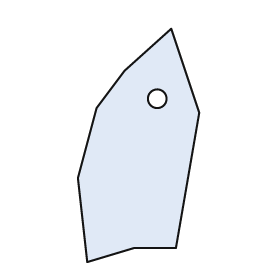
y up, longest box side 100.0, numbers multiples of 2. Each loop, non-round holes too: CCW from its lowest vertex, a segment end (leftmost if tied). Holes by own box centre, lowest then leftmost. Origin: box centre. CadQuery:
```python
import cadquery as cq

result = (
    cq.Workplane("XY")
    .moveTo(-22.0, -50.0)
    .lineTo(-2.0, -44.0)
    .lineTo(16.0, -44.0)
    .lineTo(26.0, 14.0)
    .lineTo(14.0, 50.0)
    .lineTo(-6.0, 32.0)
    .lineTo(-18.0, 16.0)
    .lineTo(-26.0, -14.0)
    .close()
    .moveTo(8.0, 20.0)
    .circle(4.0)
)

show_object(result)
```